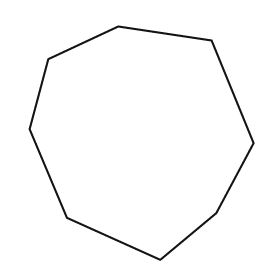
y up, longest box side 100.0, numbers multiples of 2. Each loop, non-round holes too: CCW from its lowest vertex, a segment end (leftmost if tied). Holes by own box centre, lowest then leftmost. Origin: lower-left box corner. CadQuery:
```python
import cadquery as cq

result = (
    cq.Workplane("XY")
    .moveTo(56.0, 0.0)
    .lineTo(80.0, 20.0)
    .lineTo(96.0, 50.0)
    .lineTo(78.0, 94.0)
    .lineTo(38.0, 100.0)
    .lineTo(8.0, 86.0)
    .lineTo(0.0, 56.0)
    .lineTo(16.0, 18.0)
    .close()
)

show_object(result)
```